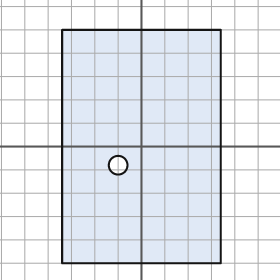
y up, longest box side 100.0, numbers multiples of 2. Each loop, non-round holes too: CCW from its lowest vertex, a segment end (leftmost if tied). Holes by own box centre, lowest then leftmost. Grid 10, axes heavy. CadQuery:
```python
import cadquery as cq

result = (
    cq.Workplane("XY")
    .moveTo(-34.0, -50.0)
    .lineTo(34.0, -50.0)
    .lineTo(34.0, 50.0)
    .lineTo(-34.0, 50.0)
    .close()
    .moveTo(-10.0, -8.0)
    .circle(4.0)
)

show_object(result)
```